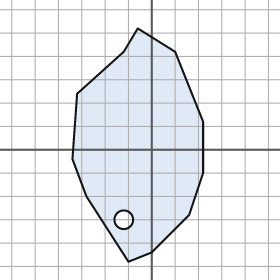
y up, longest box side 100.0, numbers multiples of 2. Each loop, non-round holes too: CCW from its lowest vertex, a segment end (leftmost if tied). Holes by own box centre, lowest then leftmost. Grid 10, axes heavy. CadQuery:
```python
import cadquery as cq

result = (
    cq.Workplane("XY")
    .moveTo(-10.0, -48.0)
    .lineTo(0.0, -44.0)
    .lineTo(16.0, -28.0)
    .lineTo(22.0, -10.0)
    .lineTo(22.0, 12.0)
    .lineTo(10.0, 42.0)
    .lineTo(-6.0, 52.0)
    .lineTo(-12.0, 42.0)
    .lineTo(-32.0, 24.0)
    .lineTo(-34.0, -4.0)
    .lineTo(-28.0, -20.0)
    .close()
    .moveTo(-12.0, -30.0)
    .circle(4.0)
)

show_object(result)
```